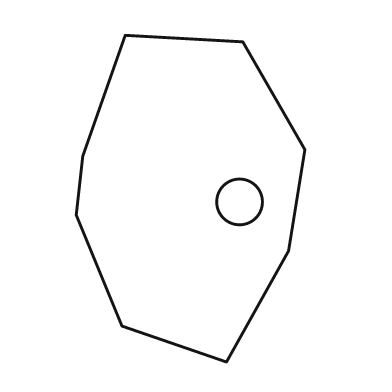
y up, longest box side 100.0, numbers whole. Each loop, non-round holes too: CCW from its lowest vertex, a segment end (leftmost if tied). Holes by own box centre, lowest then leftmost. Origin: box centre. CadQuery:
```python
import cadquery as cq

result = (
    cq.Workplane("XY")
    .moveTo(11.0, -50.0)
    .lineTo(30.0, -16.0)
    .lineTo(35.0, 15.0)
    .lineTo(16.0, 48.0)
    .lineTo(-20.0, 50.0)
    .lineTo(-33.0, 13.0)
    .lineTo(-35.0, -5.0)
    .lineTo(-21.0, -39.0)
    .close()
    .moveTo(15.0, -1.0)
    .circle(7.0)
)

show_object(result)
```